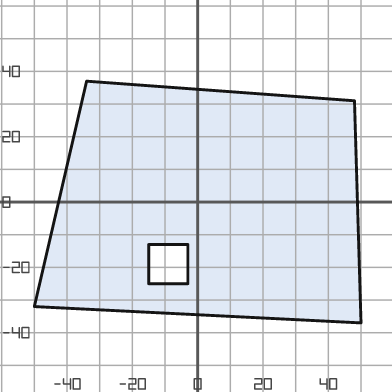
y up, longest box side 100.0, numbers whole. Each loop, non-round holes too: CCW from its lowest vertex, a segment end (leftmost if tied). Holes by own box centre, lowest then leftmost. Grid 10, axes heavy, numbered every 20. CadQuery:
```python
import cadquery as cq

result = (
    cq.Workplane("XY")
    .moveTo(50.0, -37.0)
    .lineTo(48.0, 31.0)
    .lineTo(-34.0, 37.0)
    .lineTo(-50.0, -32.0)
    .close()
    .moveTo(-15.0, -25.0)
    .lineTo(-3.0, -25.0)
    .lineTo(-3.0, -13.0)
    .lineTo(-15.0, -13.0)
    .close()
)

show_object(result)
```